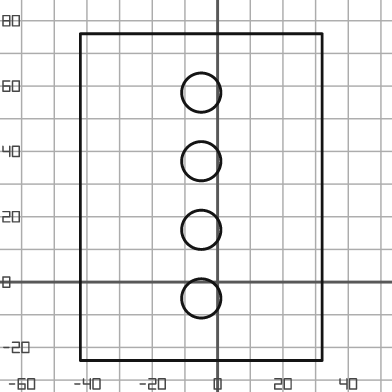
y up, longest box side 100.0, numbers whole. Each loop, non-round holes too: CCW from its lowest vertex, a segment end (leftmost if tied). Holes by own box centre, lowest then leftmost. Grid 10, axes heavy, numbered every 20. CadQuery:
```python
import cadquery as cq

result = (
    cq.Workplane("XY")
    .moveTo(-42.0, -24.0)
    .lineTo(32.0, -24.0)
    .lineTo(32.0, 76.0)
    .lineTo(-42.0, 76.0)
    .close()
    .moveTo(-5.0, -5.0)
    .circle(6.0)
    .moveTo(-5.0, 16.0)
    .circle(6.0)
    .moveTo(-5.0, 37.0)
    .circle(6.0)
    .moveTo(-5.0, 58.0)
    .circle(6.0)
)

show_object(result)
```